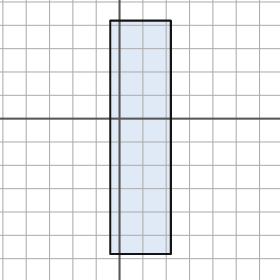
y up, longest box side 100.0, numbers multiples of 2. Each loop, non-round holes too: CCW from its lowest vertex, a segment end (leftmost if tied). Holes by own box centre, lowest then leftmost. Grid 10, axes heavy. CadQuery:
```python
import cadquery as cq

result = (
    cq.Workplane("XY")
    .moveTo(-4.0, -58.0)
    .lineTo(22.0, -58.0)
    .lineTo(22.0, 42.0)
    .lineTo(-4.0, 42.0)
    .close()
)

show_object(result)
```